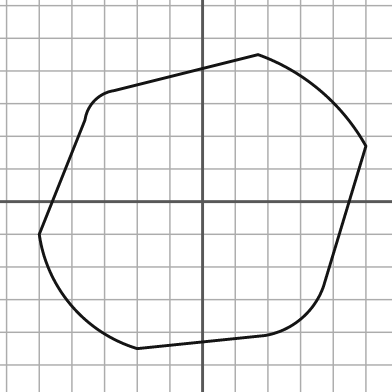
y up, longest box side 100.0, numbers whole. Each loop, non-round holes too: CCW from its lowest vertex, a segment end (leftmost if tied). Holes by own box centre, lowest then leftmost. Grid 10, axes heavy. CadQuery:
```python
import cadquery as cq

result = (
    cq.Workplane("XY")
    .moveTo(-20.0, -45.0)
    .lineTo(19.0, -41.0)
    .threePointArc((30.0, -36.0), (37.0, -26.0))
    .lineTo(50.0, 17.0)
    .threePointArc((36.0, 34.0), (17.0, 45.0))
    .lineTo(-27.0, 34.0)
    .threePointArc((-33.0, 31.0), (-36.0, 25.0))
    .lineTo(-50.0, -10.0)
    .threePointArc((-40.0, -32.0), (-20.0, -45.0))
    .close()
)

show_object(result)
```